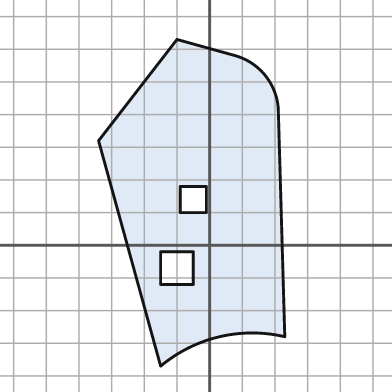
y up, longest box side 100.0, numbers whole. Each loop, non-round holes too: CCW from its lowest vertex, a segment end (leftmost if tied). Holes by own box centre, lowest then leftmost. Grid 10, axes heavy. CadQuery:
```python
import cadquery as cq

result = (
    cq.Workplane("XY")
    .moveTo(-15.0, -37.0)
    .threePointArc((3.0, -28.0), (23.0, -28.0))
    .lineTo(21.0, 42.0)
    .threePointArc((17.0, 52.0), (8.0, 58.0))
    .lineTo(-10.0, 63.0)
    .lineTo(-34.0, 32.0)
    .close()
    .moveTo(-15.0, -12.0)
    .lineTo(-5.0, -12.0)
    .lineTo(-5.0, -2.0)
    .lineTo(-15.0, -2.0)
    .close()
    .moveTo(-9.0, 10.0)
    .lineTo(-1.0, 10.0)
    .lineTo(-1.0, 18.0)
    .lineTo(-9.0, 18.0)
    .close()
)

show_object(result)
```